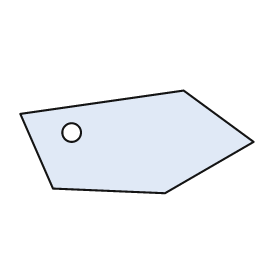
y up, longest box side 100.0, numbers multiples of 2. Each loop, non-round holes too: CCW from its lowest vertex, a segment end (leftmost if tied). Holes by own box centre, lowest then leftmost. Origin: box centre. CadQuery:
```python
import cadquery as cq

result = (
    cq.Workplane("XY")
    .moveTo(12.0, -22.0)
    .lineTo(50.0, 0.0)
    .lineTo(20.0, 22.0)
    .lineTo(-50.0, 12.0)
    .lineTo(-36.0, -20.0)
    .close()
    .moveTo(-28.0, 4.0)
    .circle(4.0)
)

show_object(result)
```